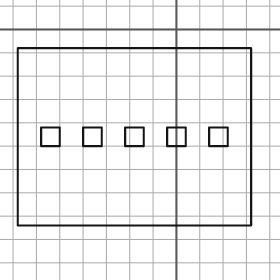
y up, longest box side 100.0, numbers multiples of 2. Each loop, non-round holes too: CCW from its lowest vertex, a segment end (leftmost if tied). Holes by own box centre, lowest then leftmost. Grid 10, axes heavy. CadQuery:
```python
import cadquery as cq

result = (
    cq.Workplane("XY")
    .moveTo(-68.0, -84.0)
    .lineTo(32.0, -84.0)
    .lineTo(32.0, -8.0)
    .lineTo(-68.0, -8.0)
    .close()
    .moveTo(-58.0, -50.0)
    .lineTo(-50.0, -50.0)
    .lineTo(-50.0, -42.0)
    .lineTo(-58.0, -42.0)
    .close()
    .moveTo(-40.0, -50.0)
    .lineTo(-32.0, -50.0)
    .lineTo(-32.0, -42.0)
    .lineTo(-40.0, -42.0)
    .close()
    .moveTo(-22.0, -50.0)
    .lineTo(-14.0, -50.0)
    .lineTo(-14.0, -42.0)
    .lineTo(-22.0, -42.0)
    .close()
    .moveTo(-4.0, -50.0)
    .lineTo(4.0, -50.0)
    .lineTo(4.0, -42.0)
    .lineTo(-4.0, -42.0)
    .close()
    .moveTo(14.0, -50.0)
    .lineTo(22.0, -50.0)
    .lineTo(22.0, -42.0)
    .lineTo(14.0, -42.0)
    .close()
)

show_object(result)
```